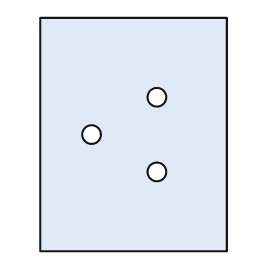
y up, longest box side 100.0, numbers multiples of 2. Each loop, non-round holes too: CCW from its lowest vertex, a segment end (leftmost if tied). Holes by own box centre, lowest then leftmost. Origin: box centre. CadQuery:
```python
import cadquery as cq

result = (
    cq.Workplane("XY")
    .moveTo(-40.0, -50.0)
    .lineTo(40.0, -50.0)
    .lineTo(40.0, 50.0)
    .lineTo(-40.0, 50.0)
    .close()
    .moveTo(10.0, -16.0)
    .circle(4.0)
    .moveTo(-18.0, 0.0)
    .circle(4.0)
    .moveTo(10.0, 16.0)
    .circle(4.0)
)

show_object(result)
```